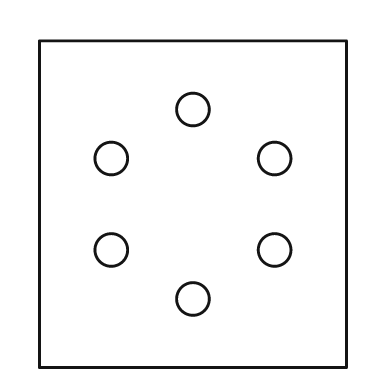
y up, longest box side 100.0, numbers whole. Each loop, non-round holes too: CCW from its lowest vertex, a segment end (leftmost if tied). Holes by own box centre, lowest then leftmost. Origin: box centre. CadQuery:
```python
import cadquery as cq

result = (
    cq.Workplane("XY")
    .moveTo(-47.0, -50.0)
    .lineTo(47.0, -50.0)
    .lineTo(47.0, 50.0)
    .lineTo(-47.0, 50.0)
    .close()
    .moveTo(0.0, -29.0)
    .circle(5.0)
    .moveTo(-25.0, -14.0)
    .circle(5.0)
    .moveTo(25.0, -14.0)
    .circle(5.0)
    .moveTo(-25.0, 14.0)
    .circle(5.0)
    .moveTo(25.0, 14.0)
    .circle(5.0)
    .moveTo(0.0, 29.0)
    .circle(5.0)
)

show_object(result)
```